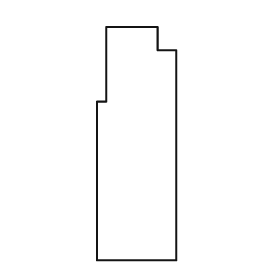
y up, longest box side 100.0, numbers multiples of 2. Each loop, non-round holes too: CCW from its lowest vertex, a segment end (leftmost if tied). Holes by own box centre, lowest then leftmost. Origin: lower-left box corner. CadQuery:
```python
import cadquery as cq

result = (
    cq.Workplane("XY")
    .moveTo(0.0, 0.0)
    .lineTo(34.0, 0.0)
    .lineTo(34.0, 90.0)
    .lineTo(26.0, 90.0)
    .lineTo(26.0, 100.0)
    .lineTo(4.0, 100.0)
    .lineTo(4.0, 68.0)
    .lineTo(0.0, 68.0)
    .close()
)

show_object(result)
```